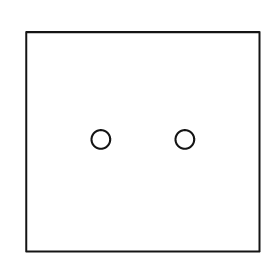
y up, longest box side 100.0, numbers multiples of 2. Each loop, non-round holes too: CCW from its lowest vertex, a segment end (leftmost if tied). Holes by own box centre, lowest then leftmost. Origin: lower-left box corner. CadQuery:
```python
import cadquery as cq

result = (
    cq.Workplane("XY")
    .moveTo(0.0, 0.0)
    .lineTo(100.0, 0.0)
    .lineTo(100.0, 94.0)
    .lineTo(0.0, 94.0)
    .close()
    .moveTo(32.0, 48.0)
    .circle(4.0)
    .moveTo(68.0, 48.0)
    .circle(4.0)
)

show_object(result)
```